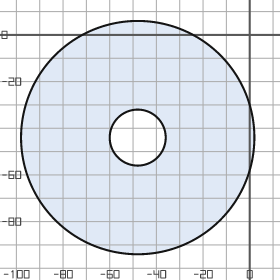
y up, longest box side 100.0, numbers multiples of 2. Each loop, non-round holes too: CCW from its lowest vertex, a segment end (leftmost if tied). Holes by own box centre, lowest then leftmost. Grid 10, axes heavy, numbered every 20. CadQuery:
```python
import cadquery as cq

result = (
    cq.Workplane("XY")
    .moveTo(-48.0, -44.0)
    .circle(50.0)
    .moveTo(-48.0, -44.0)
    .circle(12.0)
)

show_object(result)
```